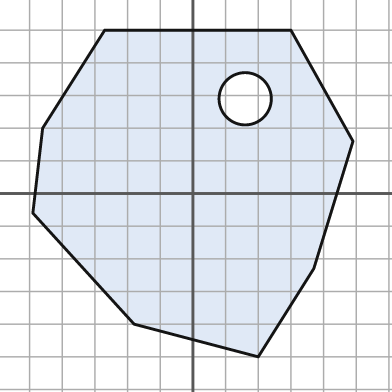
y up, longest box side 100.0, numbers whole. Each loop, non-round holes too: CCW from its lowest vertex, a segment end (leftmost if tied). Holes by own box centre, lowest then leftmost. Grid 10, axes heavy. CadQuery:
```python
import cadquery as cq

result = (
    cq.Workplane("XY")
    .moveTo(20.0, -50.0)
    .lineTo(37.0, -23.0)
    .lineTo(49.0, 16.0)
    .lineTo(30.0, 50.0)
    .lineTo(-27.0, 50.0)
    .lineTo(-46.0, 20.0)
    .lineTo(-49.0, -6.0)
    .lineTo(-18.0, -40.0)
    .close()
    .moveTo(16.0, 29.0)
    .circle(8.0)
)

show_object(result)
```